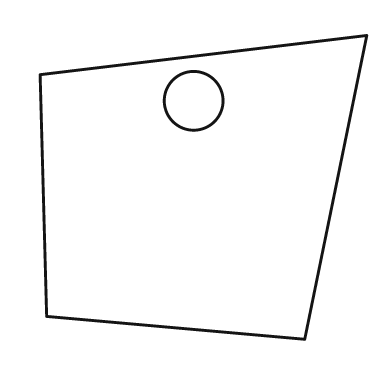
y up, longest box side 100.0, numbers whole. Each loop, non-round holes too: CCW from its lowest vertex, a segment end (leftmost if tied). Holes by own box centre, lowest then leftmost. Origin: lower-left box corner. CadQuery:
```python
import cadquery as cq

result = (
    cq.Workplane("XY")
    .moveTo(81.0, 0.0)
    .lineTo(100.0, 93.0)
    .lineTo(0.0, 81.0)
    .lineTo(2.0, 7.0)
    .close()
    .moveTo(47.0, 73.0)
    .circle(9.0)
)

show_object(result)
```